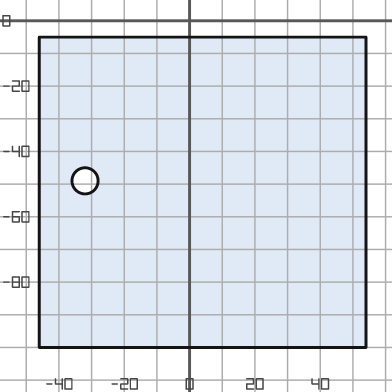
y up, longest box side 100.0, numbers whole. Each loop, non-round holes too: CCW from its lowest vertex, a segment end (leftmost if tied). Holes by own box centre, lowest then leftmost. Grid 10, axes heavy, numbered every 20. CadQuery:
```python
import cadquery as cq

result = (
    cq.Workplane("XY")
    .moveTo(-46.0, -100.0)
    .lineTo(54.0, -100.0)
    .lineTo(54.0, -5.0)
    .lineTo(-46.0, -5.0)
    .close()
    .moveTo(-32.0, -49.0)
    .circle(4.0)
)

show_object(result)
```